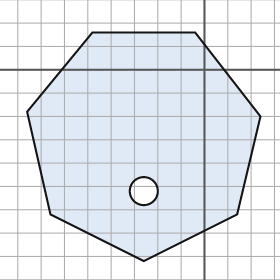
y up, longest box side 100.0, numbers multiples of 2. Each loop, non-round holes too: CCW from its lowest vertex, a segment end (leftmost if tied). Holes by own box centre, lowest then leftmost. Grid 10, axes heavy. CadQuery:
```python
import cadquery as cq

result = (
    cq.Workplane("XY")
    .moveTo(-26.0, -82.0)
    .lineTo(14.0, -62.0)
    .lineTo(24.0, -20.0)
    .lineTo(-4.0, 16.0)
    .lineTo(-48.0, 16.0)
    .lineTo(-76.0, -18.0)
    .lineTo(-66.0, -62.0)
    .close()
    .moveTo(-26.0, -52.0)
    .circle(6.0)
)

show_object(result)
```